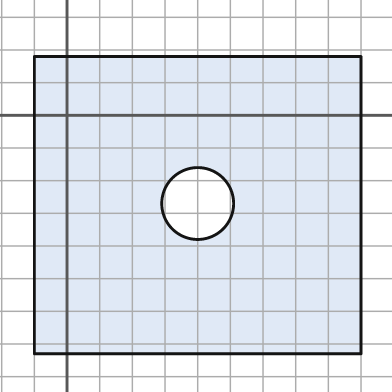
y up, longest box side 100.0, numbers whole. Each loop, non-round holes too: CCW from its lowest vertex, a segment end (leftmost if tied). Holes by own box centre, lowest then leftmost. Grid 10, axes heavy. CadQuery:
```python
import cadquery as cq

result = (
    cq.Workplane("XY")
    .moveTo(-10.0, -73.0)
    .lineTo(90.0, -73.0)
    .lineTo(90.0, 18.0)
    .lineTo(-10.0, 18.0)
    .close()
    .moveTo(40.0, -27.0)
    .circle(11.0)
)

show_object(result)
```